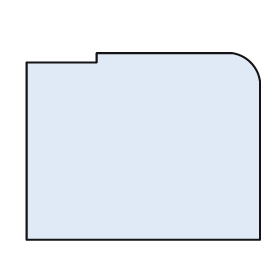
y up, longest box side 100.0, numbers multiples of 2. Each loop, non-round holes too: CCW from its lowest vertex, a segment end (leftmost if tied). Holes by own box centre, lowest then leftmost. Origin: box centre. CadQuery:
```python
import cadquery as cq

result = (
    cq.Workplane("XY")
    .moveTo(-50.0, -40.0)
    .lineTo(50.0, -40.0)
    .lineTo(50.0, 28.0)
    .threePointArc((46.0, 36.0), (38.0, 40.0))
    .lineTo(-20.0, 40.0)
    .lineTo(-20.0, 36.0)
    .lineTo(-50.0, 36.0)
    .close()
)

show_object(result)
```